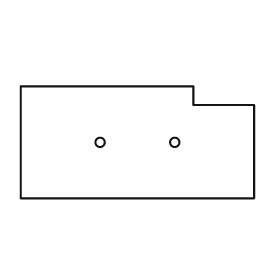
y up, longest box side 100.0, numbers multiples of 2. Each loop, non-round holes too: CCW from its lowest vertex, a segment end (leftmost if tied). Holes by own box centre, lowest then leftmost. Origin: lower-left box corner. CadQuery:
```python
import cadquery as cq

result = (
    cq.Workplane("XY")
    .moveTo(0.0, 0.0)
    .lineTo(100.0, 0.0)
    .lineTo(100.0, 40.0)
    .lineTo(74.0, 40.0)
    .lineTo(74.0, 48.0)
    .lineTo(0.0, 48.0)
    .close()
    .moveTo(34.0, 24.0)
    .circle(2.0)
    .moveTo(66.0, 24.0)
    .circle(2.0)
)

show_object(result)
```